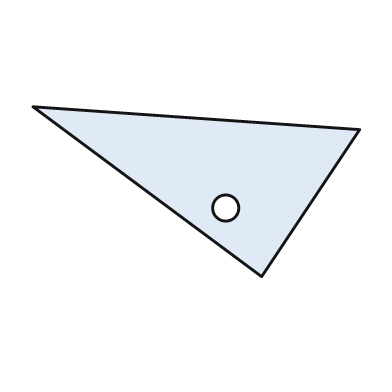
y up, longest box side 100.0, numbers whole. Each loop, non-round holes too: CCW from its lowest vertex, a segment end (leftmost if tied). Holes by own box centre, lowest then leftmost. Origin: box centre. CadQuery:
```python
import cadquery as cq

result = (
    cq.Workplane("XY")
    .moveTo(20.0, -26.0)
    .lineTo(50.0, 19.0)
    .lineTo(-50.0, 26.0)
    .close()
    .moveTo(9.0, -5.0)
    .circle(4.0)
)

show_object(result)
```